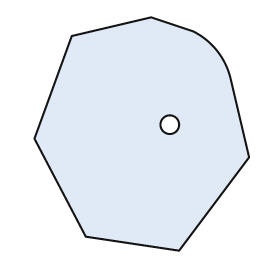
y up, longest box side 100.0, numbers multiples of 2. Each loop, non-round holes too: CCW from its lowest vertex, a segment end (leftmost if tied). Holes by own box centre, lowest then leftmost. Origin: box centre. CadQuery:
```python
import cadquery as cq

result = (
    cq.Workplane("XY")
    .moveTo(16.0, -50.0)
    .lineTo(46.0, -10.0)
    .lineTo(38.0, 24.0)
    .threePointArc((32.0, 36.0), (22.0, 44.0))
    .lineTo(4.0, 50.0)
    .lineTo(-30.0, 42.0)
    .lineTo(-46.0, -2.0)
    .lineTo(-24.0, -44.0)
    .close()
    .moveTo(12.0, 4.0)
    .circle(4.0)
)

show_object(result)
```